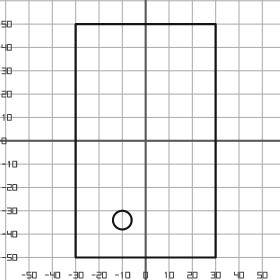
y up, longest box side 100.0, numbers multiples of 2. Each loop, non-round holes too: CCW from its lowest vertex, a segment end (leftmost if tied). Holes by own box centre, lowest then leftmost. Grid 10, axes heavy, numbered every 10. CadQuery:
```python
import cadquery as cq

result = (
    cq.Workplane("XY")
    .moveTo(-30.0, -50.0)
    .lineTo(30.0, -50.0)
    .lineTo(30.0, 50.0)
    .lineTo(-30.0, 50.0)
    .close()
    .moveTo(-10.0, -34.0)
    .circle(4.0)
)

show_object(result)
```